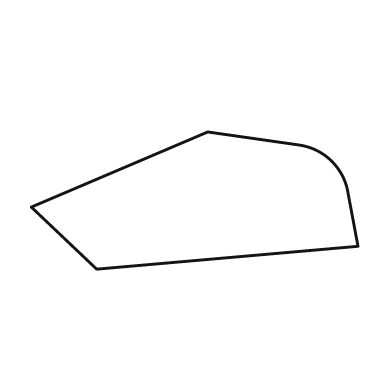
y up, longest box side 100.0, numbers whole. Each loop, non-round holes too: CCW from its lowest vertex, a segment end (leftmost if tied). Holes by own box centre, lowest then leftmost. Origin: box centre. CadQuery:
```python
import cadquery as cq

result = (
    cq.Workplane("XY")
    .moveTo(-30.0, -21.0)
    .lineTo(50.0, -14.0)
    .lineTo(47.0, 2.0)
    .threePointArc((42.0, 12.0), (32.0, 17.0))
    .lineTo(4.0, 21.0)
    .lineTo(-50.0, -2.0)
    .close()
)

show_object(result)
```